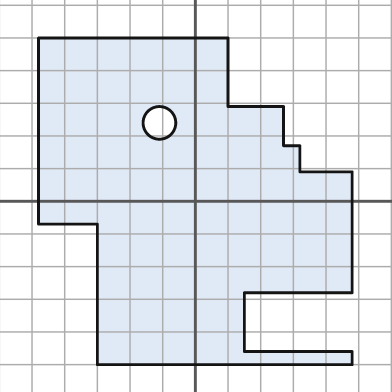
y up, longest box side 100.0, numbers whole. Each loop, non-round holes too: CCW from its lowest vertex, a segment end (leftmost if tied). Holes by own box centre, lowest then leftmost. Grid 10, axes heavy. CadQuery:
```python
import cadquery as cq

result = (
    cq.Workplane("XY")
    .moveTo(-30.0, -50.0)
    .lineTo(48.0, -50.0)
    .lineTo(48.0, -46.0)
    .lineTo(15.0, -46.0)
    .lineTo(15.0, -28.0)
    .lineTo(48.0, -28.0)
    .lineTo(48.0, 9.0)
    .lineTo(32.0, 9.0)
    .lineTo(32.0, 17.0)
    .lineTo(27.0, 17.0)
    .lineTo(27.0, 29.0)
    .lineTo(10.0, 29.0)
    .lineTo(10.0, 50.0)
    .lineTo(-48.0, 50.0)
    .lineTo(-48.0, -7.0)
    .lineTo(-30.0, -7.0)
    .close()
    .moveTo(-11.0, 24.0)
    .circle(5.0)
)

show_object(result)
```